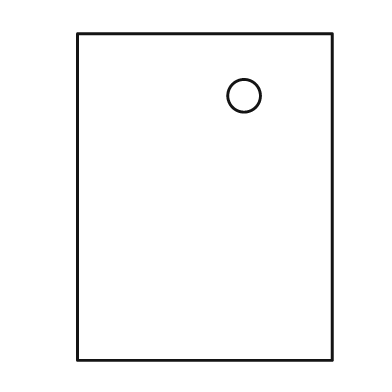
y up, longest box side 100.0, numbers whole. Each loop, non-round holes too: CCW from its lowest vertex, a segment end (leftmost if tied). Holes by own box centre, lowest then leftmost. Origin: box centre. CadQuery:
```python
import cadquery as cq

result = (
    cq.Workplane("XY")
    .moveTo(-39.0, -50.0)
    .lineTo(39.0, -50.0)
    .lineTo(39.0, 50.0)
    .lineTo(-39.0, 50.0)
    .close()
    .moveTo(12.0, 31.0)
    .circle(5.0)
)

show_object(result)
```